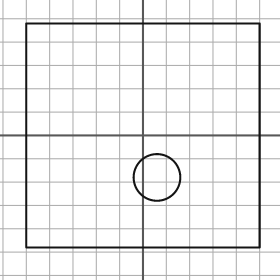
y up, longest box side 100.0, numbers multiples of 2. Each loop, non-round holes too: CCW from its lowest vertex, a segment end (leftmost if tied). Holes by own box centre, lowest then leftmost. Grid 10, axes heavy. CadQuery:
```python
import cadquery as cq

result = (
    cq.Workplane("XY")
    .moveTo(-50.0, -48.0)
    .lineTo(50.0, -48.0)
    .lineTo(50.0, 48.0)
    .lineTo(-50.0, 48.0)
    .close()
    .moveTo(6.0, -18.0)
    .circle(10.0)
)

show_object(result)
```